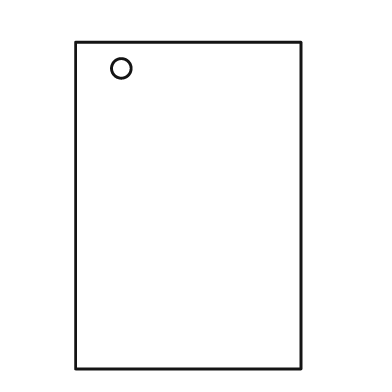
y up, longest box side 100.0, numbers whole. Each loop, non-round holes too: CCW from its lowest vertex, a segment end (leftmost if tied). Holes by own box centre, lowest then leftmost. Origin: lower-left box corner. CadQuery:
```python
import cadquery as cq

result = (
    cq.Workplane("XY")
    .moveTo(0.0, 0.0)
    .lineTo(69.0, 0.0)
    .lineTo(69.0, 100.0)
    .lineTo(0.0, 100.0)
    .close()
    .moveTo(14.0, 92.0)
    .circle(3.0)
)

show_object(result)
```